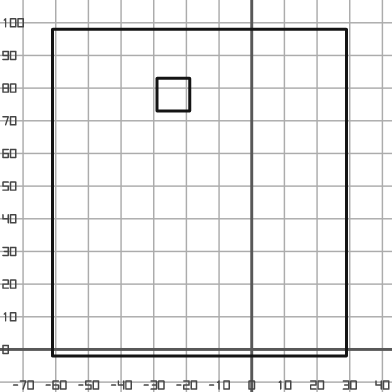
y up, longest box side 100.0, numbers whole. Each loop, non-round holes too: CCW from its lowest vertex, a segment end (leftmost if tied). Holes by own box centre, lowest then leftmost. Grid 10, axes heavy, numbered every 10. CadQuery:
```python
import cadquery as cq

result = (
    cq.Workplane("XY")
    .moveTo(-61.0, -2.0)
    .lineTo(29.0, -2.0)
    .lineTo(29.0, 98.0)
    .lineTo(-61.0, 98.0)
    .close()
    .moveTo(-29.0, 73.0)
    .lineTo(-19.0, 73.0)
    .lineTo(-19.0, 83.0)
    .lineTo(-29.0, 83.0)
    .close()
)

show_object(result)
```